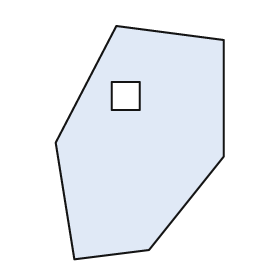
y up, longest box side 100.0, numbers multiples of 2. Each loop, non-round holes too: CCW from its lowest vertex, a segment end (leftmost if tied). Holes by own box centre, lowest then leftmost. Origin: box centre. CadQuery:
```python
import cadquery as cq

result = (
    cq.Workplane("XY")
    .moveTo(-28.0, -50.0)
    .lineTo(4.0, -46.0)
    .lineTo(36.0, -6.0)
    .lineTo(36.0, 44.0)
    .lineTo(-10.0, 50.0)
    .lineTo(-36.0, 0.0)
    .close()
    .moveTo(-12.0, 14.0)
    .lineTo(0.0, 14.0)
    .lineTo(0.0, 26.0)
    .lineTo(-12.0, 26.0)
    .close()
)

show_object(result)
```